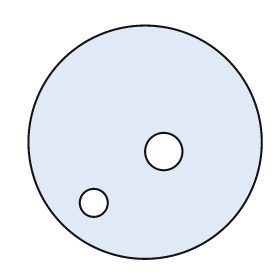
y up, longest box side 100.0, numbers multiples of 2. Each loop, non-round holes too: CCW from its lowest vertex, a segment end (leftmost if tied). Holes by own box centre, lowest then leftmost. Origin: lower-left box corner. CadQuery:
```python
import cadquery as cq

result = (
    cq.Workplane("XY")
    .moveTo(50.0, 50.0)
    .circle(50.0)
    .moveTo(28.0, 24.0)
    .circle(6.0)
    .moveTo(58.0, 46.0)
    .circle(8.0)
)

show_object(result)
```